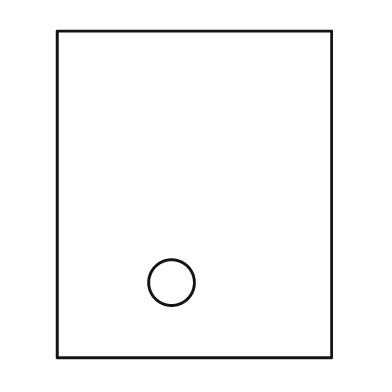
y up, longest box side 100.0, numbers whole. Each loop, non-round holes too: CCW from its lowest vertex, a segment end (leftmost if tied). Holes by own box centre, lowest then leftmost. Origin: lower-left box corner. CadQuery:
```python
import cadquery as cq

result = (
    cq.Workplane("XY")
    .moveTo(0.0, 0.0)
    .lineTo(84.0, 0.0)
    .lineTo(84.0, 100.0)
    .lineTo(0.0, 100.0)
    .close()
    .moveTo(35.0, 23.0)
    .circle(7.0)
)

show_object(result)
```